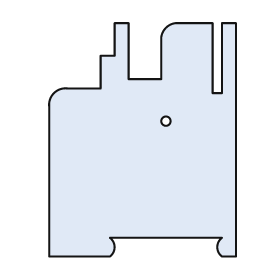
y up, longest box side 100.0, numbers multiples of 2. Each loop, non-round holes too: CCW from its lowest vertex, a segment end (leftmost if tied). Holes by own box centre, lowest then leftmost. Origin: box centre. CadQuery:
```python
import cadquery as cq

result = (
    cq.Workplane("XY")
    .moveTo(-40.0, -50.0)
    .lineTo(-14.0, -50.0)
    .threePointArc((-12.0, -46.0), (-14.0, -42.0))
    .lineTo(34.0, -42.0)
    .threePointArc((32.0, -46.0), (34.0, -50.0))
    .lineTo(40.0, -50.0)
    .lineTo(40.0, 50.0)
    .lineTo(34.0, 50.0)
    .lineTo(34.0, 20.0)
    .lineTo(30.0, 20.0)
    .lineTo(30.0, 50.0)
    .lineTo(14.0, 50.0)
    .threePointArc((10.0, 48.0), (8.0, 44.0))
    .lineTo(8.0, 26.0)
    .lineTo(-6.0, 26.0)
    .lineTo(-6.0, 50.0)
    .lineTo(-12.0, 50.0)
    .lineTo(-12.0, 36.0)
    .lineTo(-18.0, 36.0)
    .lineTo(-18.0, 22.0)
    .lineTo(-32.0, 22.0)
    .threePointArc((-38.0, 20.0), (-40.0, 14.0))
    .close()
    .moveTo(10.0, 8.0)
    .circle(2.0)
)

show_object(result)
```